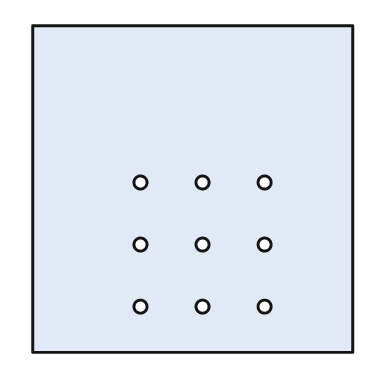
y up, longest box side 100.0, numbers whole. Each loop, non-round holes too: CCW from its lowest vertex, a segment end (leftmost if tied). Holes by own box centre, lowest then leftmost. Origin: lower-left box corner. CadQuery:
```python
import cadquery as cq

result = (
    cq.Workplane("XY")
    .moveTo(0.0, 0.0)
    .lineTo(98.0, 0.0)
    .lineTo(98.0, 100.0)
    .lineTo(0.0, 100.0)
    .close()
    .moveTo(33.0, 14.0)
    .circle(2.0)
    .moveTo(52.0, 14.0)
    .circle(2.0)
    .moveTo(71.0, 14.0)
    .circle(2.0)
    .moveTo(33.0, 33.0)
    .circle(2.0)
    .moveTo(52.0, 33.0)
    .circle(2.0)
    .moveTo(71.0, 33.0)
    .circle(2.0)
    .moveTo(33.0, 52.0)
    .circle(2.0)
    .moveTo(52.0, 52.0)
    .circle(2.0)
    .moveTo(71.0, 52.0)
    .circle(2.0)
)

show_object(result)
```